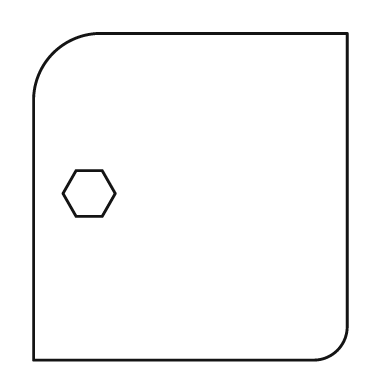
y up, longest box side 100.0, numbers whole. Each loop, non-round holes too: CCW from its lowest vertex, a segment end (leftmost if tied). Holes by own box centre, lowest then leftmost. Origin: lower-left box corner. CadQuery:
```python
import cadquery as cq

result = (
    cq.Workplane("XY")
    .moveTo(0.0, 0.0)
    .lineTo(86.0, 0.0)
    .threePointArc((93.0, 3.0), (96.0, 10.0))
    .lineTo(96.0, 100.0)
    .lineTo(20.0, 100.0)
    .threePointArc((6.0, 94.0), (0.0, 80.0))
    .close()
    .moveTo(13.0, 44.0)
    .lineTo(21.0, 44.0)
    .lineTo(25.0, 51.0)
    .lineTo(21.0, 58.0)
    .lineTo(13.0, 58.0)
    .lineTo(9.0, 51.0)
    .close()
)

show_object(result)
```